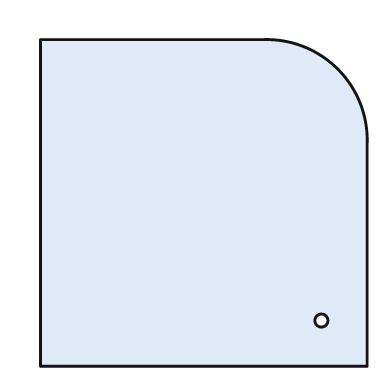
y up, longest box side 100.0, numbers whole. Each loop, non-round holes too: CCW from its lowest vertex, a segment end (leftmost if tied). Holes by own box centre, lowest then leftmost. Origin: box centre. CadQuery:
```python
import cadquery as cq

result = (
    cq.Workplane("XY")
    .moveTo(-50.0, -50.0)
    .lineTo(50.0, -50.0)
    .lineTo(50.0, 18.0)
    .threePointArc((41.0, 41.0), (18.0, 50.0))
    .lineTo(-50.0, 50.0)
    .close()
    .moveTo(36.0, -36.0)
    .circle(2.0)
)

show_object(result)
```